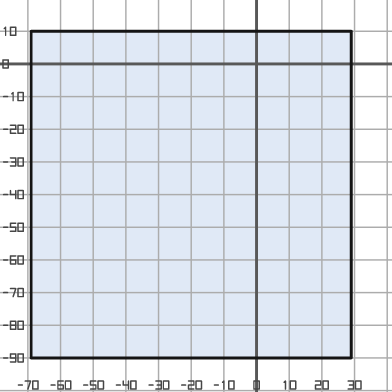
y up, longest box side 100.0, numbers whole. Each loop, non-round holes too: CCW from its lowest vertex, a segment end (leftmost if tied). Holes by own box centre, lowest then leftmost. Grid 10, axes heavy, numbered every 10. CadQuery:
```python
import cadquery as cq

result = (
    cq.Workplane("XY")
    .moveTo(-69.0, -90.0)
    .lineTo(29.0, -90.0)
    .lineTo(29.0, 10.0)
    .lineTo(-69.0, 10.0)
    .close()
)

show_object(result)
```